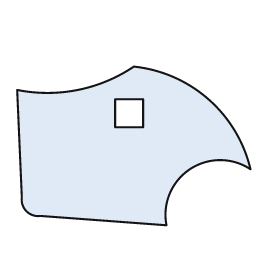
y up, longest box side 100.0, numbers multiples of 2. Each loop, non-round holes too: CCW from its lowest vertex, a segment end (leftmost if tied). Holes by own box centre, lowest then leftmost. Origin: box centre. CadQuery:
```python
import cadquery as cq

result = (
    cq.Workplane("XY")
    .moveTo(14.0, -34.0)
    .threePointArc((24.0, -10.0), (50.0, -10.0))
    .threePointArc((32.0, 20.0), (0.0, 34.0))
    .threePointArc((-24.0, 24.0), (-50.0, 24.0))
    .lineTo(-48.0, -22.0)
    .threePointArc((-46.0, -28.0), (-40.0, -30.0))
    .close()
    .moveTo(-8.0, 8.0)
    .lineTo(4.0, 8.0)
    .lineTo(4.0, 20.0)
    .lineTo(-8.0, 20.0)
    .close()
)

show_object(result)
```